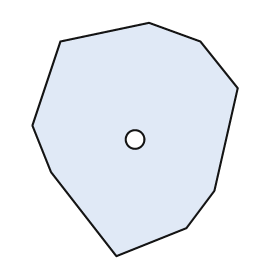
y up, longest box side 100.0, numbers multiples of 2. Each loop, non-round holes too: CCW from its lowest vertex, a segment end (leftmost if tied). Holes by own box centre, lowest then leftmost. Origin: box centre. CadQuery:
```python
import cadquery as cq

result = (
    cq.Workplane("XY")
    .moveTo(-8.0, -50.0)
    .lineTo(22.0, -38.0)
    .lineTo(34.0, -22.0)
    .lineTo(44.0, 22.0)
    .lineTo(28.0, 42.0)
    .lineTo(6.0, 50.0)
    .lineTo(-32.0, 42.0)
    .lineTo(-44.0, 6.0)
    .lineTo(-36.0, -14.0)
    .close()
    .moveTo(0.0, 0.0)
    .circle(4.0)
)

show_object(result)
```